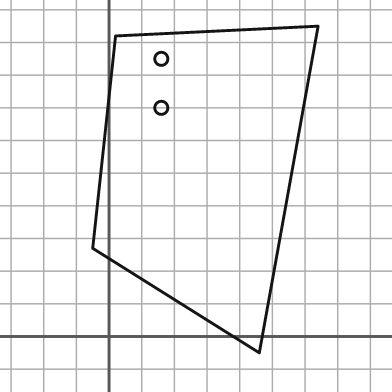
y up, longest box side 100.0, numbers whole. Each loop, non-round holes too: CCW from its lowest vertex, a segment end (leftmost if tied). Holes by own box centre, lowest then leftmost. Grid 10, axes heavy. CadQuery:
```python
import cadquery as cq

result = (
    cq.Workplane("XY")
    .moveTo(46.0, -5.0)
    .lineTo(64.0, 95.0)
    .lineTo(2.0, 92.0)
    .lineTo(-5.0, 27.0)
    .close()
    .moveTo(16.0, 70.0)
    .circle(2.0)
    .moveTo(16.0, 85.0)
    .circle(2.0)
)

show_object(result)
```